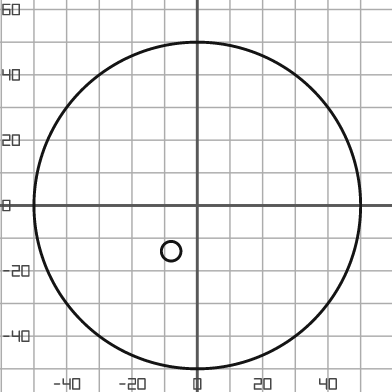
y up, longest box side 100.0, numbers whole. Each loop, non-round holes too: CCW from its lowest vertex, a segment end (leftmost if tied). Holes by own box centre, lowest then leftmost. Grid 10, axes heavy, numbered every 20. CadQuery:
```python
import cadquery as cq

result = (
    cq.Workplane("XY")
    .moveTo(0.0, 0.0)
    .circle(50.0)
    .moveTo(-8.0, -14.0)
    .circle(3.0)
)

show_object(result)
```